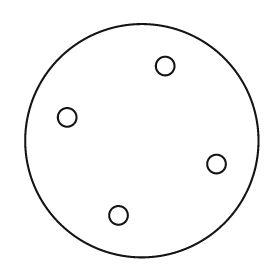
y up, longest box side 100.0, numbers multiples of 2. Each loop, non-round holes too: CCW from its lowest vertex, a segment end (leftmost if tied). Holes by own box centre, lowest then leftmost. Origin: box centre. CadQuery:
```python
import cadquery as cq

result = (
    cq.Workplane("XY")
    .moveTo(0.0, 0.0)
    .circle(50.0)
    .moveTo(-10.0, -32.0)
    .circle(4.0)
    .moveTo(32.0, -10.0)
    .circle(4.0)
    .moveTo(-32.0, 10.0)
    .circle(4.0)
    .moveTo(10.0, 32.0)
    .circle(4.0)
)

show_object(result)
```